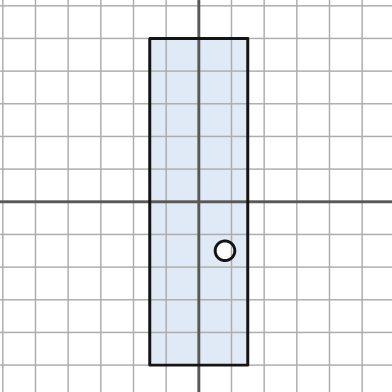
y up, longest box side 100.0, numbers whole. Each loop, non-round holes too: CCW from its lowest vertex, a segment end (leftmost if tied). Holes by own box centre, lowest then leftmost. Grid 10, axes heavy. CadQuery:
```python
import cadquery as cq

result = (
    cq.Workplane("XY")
    .moveTo(-15.0, -50.0)
    .lineTo(15.0, -50.0)
    .lineTo(15.0, 50.0)
    .lineTo(-15.0, 50.0)
    .close()
    .moveTo(8.0, -15.0)
    .circle(3.0)
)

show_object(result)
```